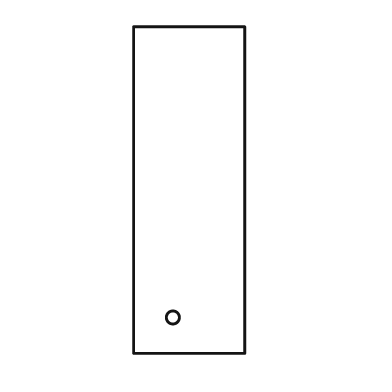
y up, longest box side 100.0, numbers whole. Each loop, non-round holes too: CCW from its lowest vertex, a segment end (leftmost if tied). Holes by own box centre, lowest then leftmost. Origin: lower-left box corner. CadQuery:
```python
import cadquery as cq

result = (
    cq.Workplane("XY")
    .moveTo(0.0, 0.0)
    .lineTo(34.0, 0.0)
    .lineTo(34.0, 100.0)
    .lineTo(0.0, 100.0)
    .close()
    .moveTo(12.0, 11.0)
    .circle(2.0)
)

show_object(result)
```